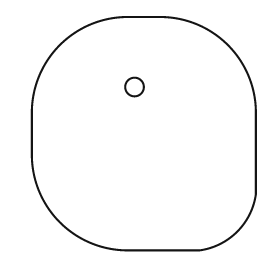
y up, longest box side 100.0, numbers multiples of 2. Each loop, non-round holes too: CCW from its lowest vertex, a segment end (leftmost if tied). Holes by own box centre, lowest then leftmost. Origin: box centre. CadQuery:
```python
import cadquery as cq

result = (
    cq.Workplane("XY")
    .moveTo(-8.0, -50.0)
    .lineTo(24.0, -50.0)
    .threePointArc((40.0, -42.0), (48.0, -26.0))
    .lineTo(48.0, 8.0)
    .threePointArc((36.0, 38.0), (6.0, 50.0))
    .lineTo(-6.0, 50.0)
    .threePointArc((-36.0, 38.0), (-48.0, 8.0))
    .lineTo(-48.0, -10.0)
    .threePointArc((-36.0, -38.0), (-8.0, -50.0))
    .close()
    .moveTo(-4.0, 20.0)
    .circle(4.0)
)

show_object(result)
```